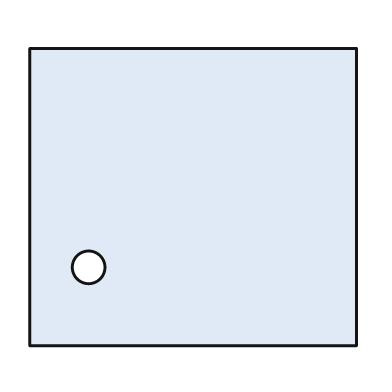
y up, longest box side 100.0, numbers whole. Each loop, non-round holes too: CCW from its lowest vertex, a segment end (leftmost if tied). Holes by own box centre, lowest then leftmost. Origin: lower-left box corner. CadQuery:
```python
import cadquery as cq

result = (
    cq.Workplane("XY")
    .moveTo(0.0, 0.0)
    .lineTo(100.0, 0.0)
    .lineTo(100.0, 91.0)
    .lineTo(0.0, 91.0)
    .close()
    .moveTo(18.0, 24.0)
    .circle(5.0)
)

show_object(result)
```